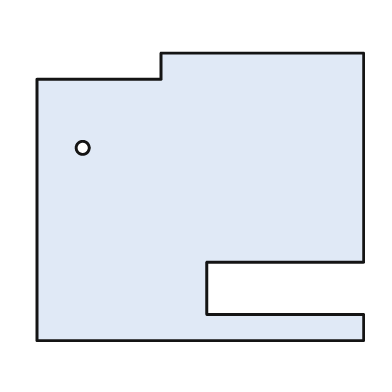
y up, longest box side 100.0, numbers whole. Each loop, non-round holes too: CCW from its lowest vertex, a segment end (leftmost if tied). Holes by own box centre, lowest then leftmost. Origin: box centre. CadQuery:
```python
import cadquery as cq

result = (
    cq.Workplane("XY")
    .moveTo(-50.0, -44.0)
    .lineTo(50.0, -44.0)
    .lineTo(50.0, -36.0)
    .lineTo(2.0, -36.0)
    .lineTo(2.0, -20.0)
    .lineTo(50.0, -20.0)
    .lineTo(50.0, 44.0)
    .lineTo(-12.0, 44.0)
    .lineTo(-12.0, 36.0)
    .lineTo(-50.0, 36.0)
    .close()
    .moveTo(-36.0, 15.0)
    .circle(2.0)
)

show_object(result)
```